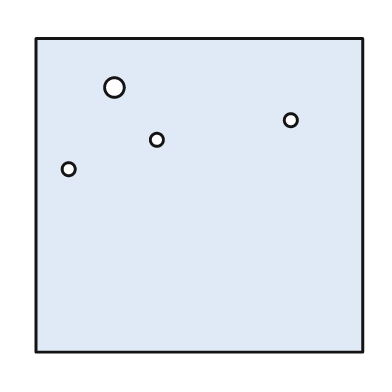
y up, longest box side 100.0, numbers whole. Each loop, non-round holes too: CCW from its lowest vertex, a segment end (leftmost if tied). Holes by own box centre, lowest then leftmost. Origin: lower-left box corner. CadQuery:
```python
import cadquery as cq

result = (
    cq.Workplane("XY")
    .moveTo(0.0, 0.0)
    .lineTo(100.0, 0.0)
    .lineTo(100.0, 96.0)
    .lineTo(0.0, 96.0)
    .close()
    .moveTo(10.0, 56.0)
    .circle(2.0)
    .moveTo(37.0, 65.0)
    .circle(2.0)
    .moveTo(78.0, 71.0)
    .circle(2.0)
    .moveTo(24.0, 81.0)
    .circle(3.0)
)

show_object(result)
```